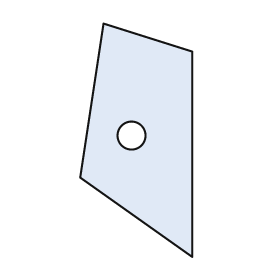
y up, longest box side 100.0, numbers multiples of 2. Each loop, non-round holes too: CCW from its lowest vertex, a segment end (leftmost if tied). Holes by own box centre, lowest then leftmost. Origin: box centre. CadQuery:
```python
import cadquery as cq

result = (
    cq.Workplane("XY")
    .moveTo(24.0, -50.0)
    .lineTo(24.0, 38.0)
    .lineTo(-14.0, 50.0)
    .lineTo(-24.0, -16.0)
    .close()
    .moveTo(-2.0, 2.0)
    .circle(6.0)
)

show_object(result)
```